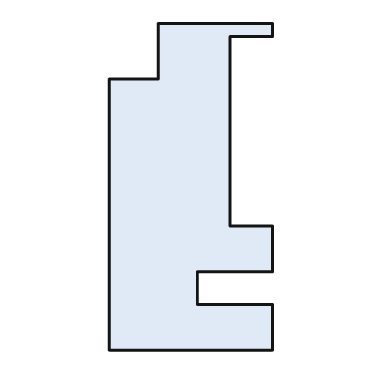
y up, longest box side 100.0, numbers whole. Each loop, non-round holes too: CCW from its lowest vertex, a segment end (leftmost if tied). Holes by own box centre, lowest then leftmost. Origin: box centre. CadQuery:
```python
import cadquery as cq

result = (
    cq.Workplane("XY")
    .moveTo(-25.0, -50.0)
    .lineTo(25.0, -50.0)
    .lineTo(25.0, -36.0)
    .lineTo(2.0, -36.0)
    .lineTo(2.0, -26.0)
    .lineTo(25.0, -26.0)
    .lineTo(25.0, -12.0)
    .lineTo(12.0, -12.0)
    .lineTo(12.0, 46.0)
    .lineTo(25.0, 46.0)
    .lineTo(25.0, 50.0)
    .lineTo(-10.0, 50.0)
    .lineTo(-10.0, 33.0)
    .lineTo(-25.0, 33.0)
    .close()
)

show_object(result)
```